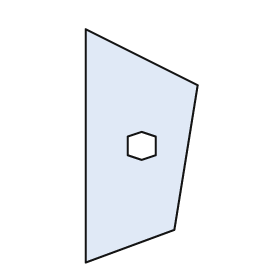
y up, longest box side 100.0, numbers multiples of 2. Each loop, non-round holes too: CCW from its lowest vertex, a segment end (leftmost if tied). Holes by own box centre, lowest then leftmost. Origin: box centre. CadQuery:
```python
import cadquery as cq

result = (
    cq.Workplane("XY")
    .moveTo(-24.0, -50.0)
    .lineTo(14.0, -36.0)
    .lineTo(24.0, 26.0)
    .lineTo(-24.0, 50.0)
    .close()
    .moveTo(0.0, -6.0)
    .lineTo(6.0, -4.0)
    .lineTo(6.0, 4.0)
    .lineTo(0.0, 6.0)
    .lineTo(-6.0, 4.0)
    .lineTo(-6.0, -4.0)
    .close()
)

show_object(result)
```